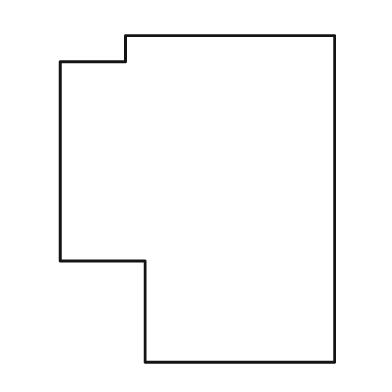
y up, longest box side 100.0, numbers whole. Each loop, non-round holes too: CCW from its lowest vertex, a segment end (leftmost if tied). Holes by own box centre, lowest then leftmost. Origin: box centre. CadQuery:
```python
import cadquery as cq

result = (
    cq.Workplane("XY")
    .moveTo(-16.0, -50.0)
    .lineTo(42.0, -50.0)
    .lineTo(42.0, 50.0)
    .lineTo(-22.0, 50.0)
    .lineTo(-22.0, 42.0)
    .lineTo(-42.0, 42.0)
    .lineTo(-42.0, -19.0)
    .lineTo(-16.0, -19.0)
    .close()
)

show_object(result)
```